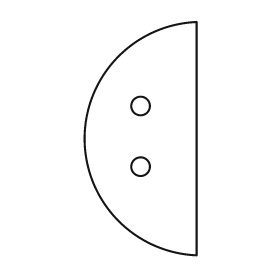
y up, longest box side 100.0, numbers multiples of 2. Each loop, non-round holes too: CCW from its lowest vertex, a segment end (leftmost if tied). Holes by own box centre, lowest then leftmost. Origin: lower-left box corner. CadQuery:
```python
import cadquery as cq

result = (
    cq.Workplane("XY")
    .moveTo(48.0, 0.0)
    .lineTo(48.0, 100.0)
    .threePointArc((0.0, 50.0), (48.0, 0.0))
    .close()
    .moveTo(24.0, 38.0)
    .circle(4.0)
    .moveTo(24.0, 64.0)
    .circle(4.0)
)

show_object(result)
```